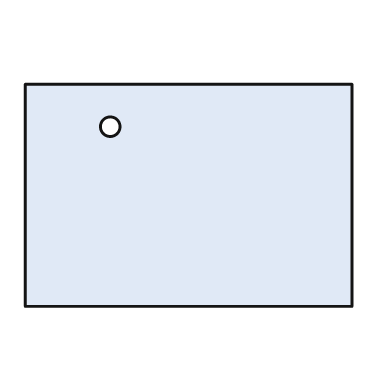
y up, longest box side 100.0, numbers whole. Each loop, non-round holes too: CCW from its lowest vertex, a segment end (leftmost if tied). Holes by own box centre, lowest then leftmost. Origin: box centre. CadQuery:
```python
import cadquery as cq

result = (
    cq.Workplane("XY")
    .moveTo(-50.0, -34.0)
    .lineTo(50.0, -34.0)
    .lineTo(50.0, 34.0)
    .lineTo(-50.0, 34.0)
    .close()
    .moveTo(-24.0, 21.0)
    .circle(3.0)
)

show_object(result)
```